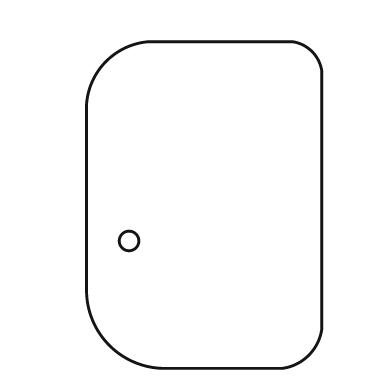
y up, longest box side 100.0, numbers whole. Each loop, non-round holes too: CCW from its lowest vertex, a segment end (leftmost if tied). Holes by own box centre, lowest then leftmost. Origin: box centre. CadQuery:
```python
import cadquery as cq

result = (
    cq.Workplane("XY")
    .moveTo(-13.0, -50.0)
    .lineTo(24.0, -50.0)
    .threePointArc((32.0, -46.0), (36.0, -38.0))
    .lineTo(36.0, 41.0)
    .threePointArc((33.0, 47.0), (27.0, 50.0))
    .lineTo(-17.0, 50.0)
    .threePointArc((-30.0, 44.0), (-36.0, 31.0))
    .lineTo(-36.0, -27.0)
    .threePointArc((-29.0, -43.0), (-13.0, -50.0))
    .close()
    .moveTo(-23.0, -11.0)
    .circle(3.0)
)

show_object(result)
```